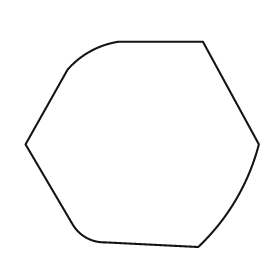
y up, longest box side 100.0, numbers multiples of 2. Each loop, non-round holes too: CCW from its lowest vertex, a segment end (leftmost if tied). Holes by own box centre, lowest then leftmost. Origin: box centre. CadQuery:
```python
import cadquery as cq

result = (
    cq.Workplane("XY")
    .moveTo(24.0, -44.0)
    .threePointArc((40.0, -24.0), (50.0, 0.0))
    .lineTo(26.0, 44.0)
    .lineTo(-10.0, 44.0)
    .threePointArc((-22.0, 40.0), (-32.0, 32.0))
    .lineTo(-50.0, 0.0)
    .lineTo(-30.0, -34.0)
    .threePointArc((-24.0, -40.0), (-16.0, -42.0))
    .close()
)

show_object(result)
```